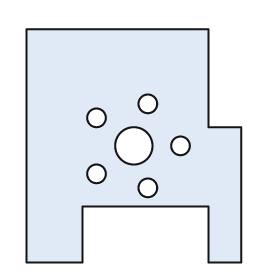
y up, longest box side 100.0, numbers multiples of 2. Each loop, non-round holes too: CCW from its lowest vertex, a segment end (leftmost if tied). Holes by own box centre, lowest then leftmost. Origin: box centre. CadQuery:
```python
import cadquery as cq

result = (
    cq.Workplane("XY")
    .moveTo(-46.0, -50.0)
    .lineTo(-22.0, -50.0)
    .lineTo(-22.0, -26.0)
    .lineTo(32.0, -26.0)
    .lineTo(32.0, -50.0)
    .lineTo(46.0, -50.0)
    .lineTo(46.0, 8.0)
    .lineTo(32.0, 8.0)
    .lineTo(32.0, 50.0)
    .lineTo(-46.0, 50.0)
    .close()
    .moveTo(6.0, -18.0)
    .circle(4.0)
    .moveTo(-16.0, -12.0)
    .circle(4.0)
    .moveTo(0.0, 0.0)
    .circle(8.0)
    .moveTo(20.0, 0.0)
    .circle(4.0)
    .moveTo(-16.0, 12.0)
    .circle(4.0)
    .moveTo(6.0, 18.0)
    .circle(4.0)
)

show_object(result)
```